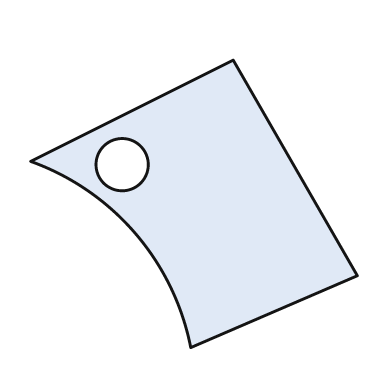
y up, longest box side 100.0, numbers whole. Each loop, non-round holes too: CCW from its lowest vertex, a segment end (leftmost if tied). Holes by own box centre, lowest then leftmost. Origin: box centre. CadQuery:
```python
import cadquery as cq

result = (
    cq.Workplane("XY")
    .moveTo(-1.0, -44.0)
    .lineTo(50.0, -22.0)
    .lineTo(12.0, 44.0)
    .lineTo(-50.0, 13.0)
    .threePointArc((-18.0, -9.0), (-1.0, -44.0))
    .close()
    .moveTo(-22.0, 12.0)
    .circle(8.0)
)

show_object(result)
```